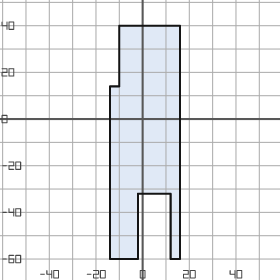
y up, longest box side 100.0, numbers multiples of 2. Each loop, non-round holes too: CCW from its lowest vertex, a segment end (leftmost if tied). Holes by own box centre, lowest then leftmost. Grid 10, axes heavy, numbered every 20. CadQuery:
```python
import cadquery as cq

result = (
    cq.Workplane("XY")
    .moveTo(-14.0, -60.0)
    .lineTo(-2.0, -60.0)
    .lineTo(-2.0, -32.0)
    .lineTo(12.0, -32.0)
    .lineTo(12.0, -60.0)
    .lineTo(16.0, -60.0)
    .lineTo(16.0, 40.0)
    .lineTo(-10.0, 40.0)
    .lineTo(-10.0, 14.0)
    .lineTo(-14.0, 14.0)
    .close()
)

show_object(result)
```